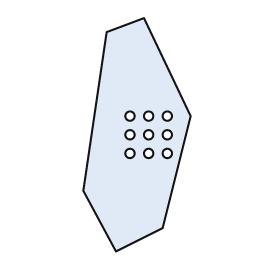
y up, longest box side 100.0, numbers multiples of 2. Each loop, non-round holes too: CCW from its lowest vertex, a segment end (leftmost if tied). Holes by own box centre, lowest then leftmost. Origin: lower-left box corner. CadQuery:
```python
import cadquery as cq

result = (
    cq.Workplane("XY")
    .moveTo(14.0, 0.0)
    .lineTo(34.0, 10.0)
    .lineTo(46.0, 58.0)
    .lineTo(26.0, 100.0)
    .lineTo(10.0, 94.0)
    .lineTo(0.0, 26.0)
    .close()
    .moveTo(20.0, 42.0)
    .circle(2.0)
    .moveTo(28.0, 42.0)
    .circle(2.0)
    .moveTo(36.0, 42.0)
    .circle(2.0)
    .moveTo(20.0, 50.0)
    .circle(2.0)
    .moveTo(28.0, 50.0)
    .circle(2.0)
    .moveTo(36.0, 50.0)
    .circle(2.0)
    .moveTo(20.0, 58.0)
    .circle(2.0)
    .moveTo(28.0, 58.0)
    .circle(2.0)
    .moveTo(36.0, 58.0)
    .circle(2.0)
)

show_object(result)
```